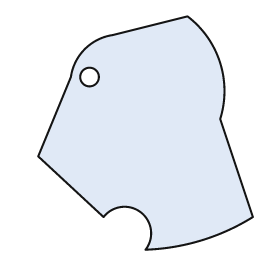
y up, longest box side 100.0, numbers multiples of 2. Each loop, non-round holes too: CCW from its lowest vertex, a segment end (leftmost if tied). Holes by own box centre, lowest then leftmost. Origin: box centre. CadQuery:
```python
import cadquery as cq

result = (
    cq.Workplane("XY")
    .moveTo(0.0, -50.0)
    .threePointArc((24.0, -46.0), (46.0, -36.0))
    .lineTo(32.0, 6.0)
    .threePointArc((32.0, 30.0), (18.0, 50.0))
    .lineTo(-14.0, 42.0)
    .threePointArc((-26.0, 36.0), (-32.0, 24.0))
    .lineTo(-46.0, -10.0)
    .lineTo(-18.0, -36.0)
    .threePointArc((-2.0, -34.0), (0.0, -50.0))
    .close()
    .moveTo(-24.0, 24.0)
    .circle(4.0)
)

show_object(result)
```